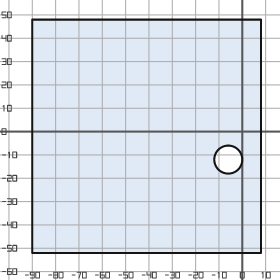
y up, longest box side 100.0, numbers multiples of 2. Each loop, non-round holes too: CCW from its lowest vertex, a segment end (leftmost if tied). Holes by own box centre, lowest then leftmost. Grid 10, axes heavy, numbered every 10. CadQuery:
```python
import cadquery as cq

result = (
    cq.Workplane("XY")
    .moveTo(-90.0, -52.0)
    .lineTo(8.0, -52.0)
    .lineTo(8.0, 48.0)
    .lineTo(-90.0, 48.0)
    .close()
    .moveTo(-6.0, -12.0)
    .circle(6.0)
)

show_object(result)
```